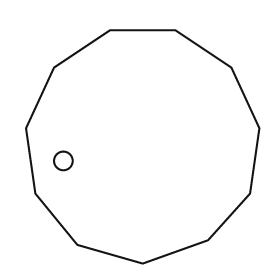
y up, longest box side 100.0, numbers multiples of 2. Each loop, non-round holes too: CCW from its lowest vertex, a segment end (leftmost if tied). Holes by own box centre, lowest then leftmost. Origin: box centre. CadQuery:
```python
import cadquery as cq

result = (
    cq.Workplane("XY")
    .moveTo(0.0, -50.0)
    .lineTo(28.0, -40.0)
    .lineTo(46.0, -20.0)
    .lineTo(50.0, 8.0)
    .lineTo(38.0, 34.0)
    .lineTo(14.0, 50.0)
    .lineTo(-14.0, 50.0)
    .lineTo(-38.0, 34.0)
    .lineTo(-50.0, 8.0)
    .lineTo(-46.0, -20.0)
    .lineTo(-28.0, -42.0)
    .close()
    .moveTo(-34.0, -6.0)
    .circle(4.0)
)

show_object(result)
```